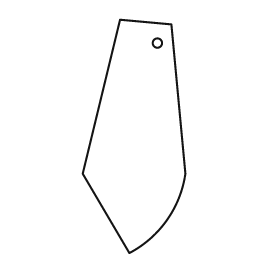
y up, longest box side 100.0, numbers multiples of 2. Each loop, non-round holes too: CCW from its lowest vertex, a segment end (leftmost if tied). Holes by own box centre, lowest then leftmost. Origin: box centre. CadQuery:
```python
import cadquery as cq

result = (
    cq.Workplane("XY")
    .moveTo(-2.0, -50.0)
    .threePointArc((14.0, -36.0), (22.0, -16.0))
    .lineTo(16.0, 48.0)
    .lineTo(-6.0, 50.0)
    .lineTo(-22.0, -16.0)
    .close()
    .moveTo(10.0, 40.0)
    .circle(2.0)
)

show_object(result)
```